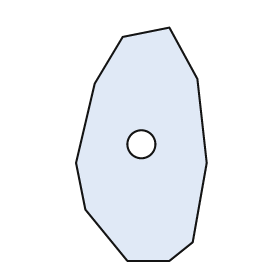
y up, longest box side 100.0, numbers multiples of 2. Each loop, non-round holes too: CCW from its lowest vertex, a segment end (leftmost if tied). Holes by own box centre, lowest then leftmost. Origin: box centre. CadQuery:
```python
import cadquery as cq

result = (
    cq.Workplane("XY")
    .moveTo(-6.0, -50.0)
    .lineTo(12.0, -50.0)
    .lineTo(22.0, -42.0)
    .lineTo(28.0, -8.0)
    .lineTo(24.0, 28.0)
    .lineTo(12.0, 50.0)
    .lineTo(-8.0, 46.0)
    .lineTo(-20.0, 26.0)
    .lineTo(-28.0, -8.0)
    .lineTo(-24.0, -28.0)
    .close()
    .moveTo(0.0, 0.0)
    .circle(6.0)
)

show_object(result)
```